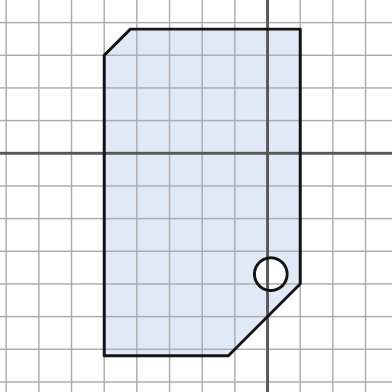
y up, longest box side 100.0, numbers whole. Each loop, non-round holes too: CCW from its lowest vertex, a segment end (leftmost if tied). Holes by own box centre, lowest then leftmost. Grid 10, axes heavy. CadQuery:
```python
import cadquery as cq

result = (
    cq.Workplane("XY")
    .moveTo(-50.0, -62.0)
    .lineTo(-12.0, -62.0)
    .lineTo(10.0, -40.0)
    .lineTo(10.0, 38.0)
    .lineTo(-42.0, 38.0)
    .lineTo(-50.0, 30.0)
    .close()
    .moveTo(1.0, -37.0)
    .circle(5.0)
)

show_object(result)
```